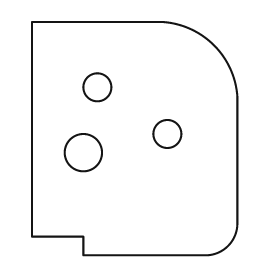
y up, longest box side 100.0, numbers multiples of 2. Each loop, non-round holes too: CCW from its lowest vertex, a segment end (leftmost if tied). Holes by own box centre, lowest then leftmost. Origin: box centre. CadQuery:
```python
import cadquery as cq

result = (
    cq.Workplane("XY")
    .moveTo(-22.0, -50.0)
    .lineTo(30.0, -50.0)
    .threePointArc((40.0, -46.0), (44.0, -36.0))
    .lineTo(44.0, 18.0)
    .threePointArc((34.0, 40.0), (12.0, 50.0))
    .lineTo(-44.0, 50.0)
    .lineTo(-44.0, -42.0)
    .lineTo(-22.0, -42.0)
    .close()
    .moveTo(-22.0, -6.0)
    .circle(8.0)
    .moveTo(14.0, 2.0)
    .circle(6.0)
    .moveTo(-16.0, 22.0)
    .circle(6.0)
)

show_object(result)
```